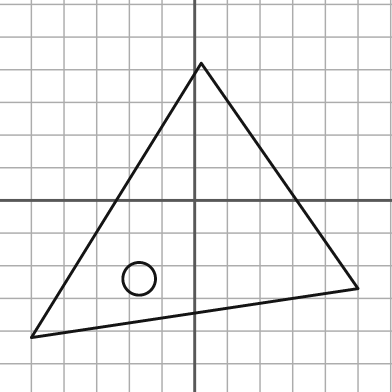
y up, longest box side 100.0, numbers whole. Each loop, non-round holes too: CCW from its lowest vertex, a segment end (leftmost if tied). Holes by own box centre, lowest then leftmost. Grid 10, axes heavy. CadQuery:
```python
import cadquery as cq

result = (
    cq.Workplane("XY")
    .moveTo(-50.0, -42.0)
    .lineTo(50.0, -27.0)
    .lineTo(2.0, 42.0)
    .close()
    .moveTo(-17.0, -24.0)
    .circle(5.0)
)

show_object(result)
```